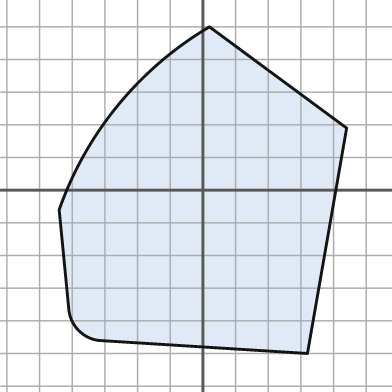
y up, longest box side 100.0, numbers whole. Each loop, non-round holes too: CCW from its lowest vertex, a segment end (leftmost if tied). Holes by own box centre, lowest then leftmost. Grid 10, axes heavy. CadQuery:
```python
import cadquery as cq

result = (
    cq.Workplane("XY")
    .moveTo(32.0, -50.0)
    .lineTo(44.0, 19.0)
    .lineTo(2.0, 50.0)
    .threePointArc((-26.0, 26.0), (-44.0, -6.0))
    .lineTo(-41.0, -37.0)
    .threePointArc((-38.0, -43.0), (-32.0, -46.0))
    .close()
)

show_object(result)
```